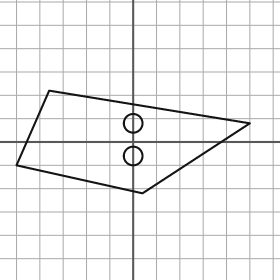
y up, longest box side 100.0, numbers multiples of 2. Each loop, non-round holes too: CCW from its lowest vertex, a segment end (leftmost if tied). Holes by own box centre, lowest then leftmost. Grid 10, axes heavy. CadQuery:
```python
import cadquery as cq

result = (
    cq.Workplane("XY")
    .moveTo(4.0, -22.0)
    .lineTo(50.0, 8.0)
    .lineTo(-36.0, 22.0)
    .lineTo(-50.0, -10.0)
    .close()
    .moveTo(0.0, -6.0)
    .circle(4.0)
    .moveTo(0.0, 8.0)
    .circle(4.0)
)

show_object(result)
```